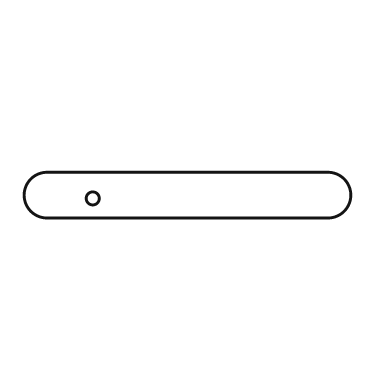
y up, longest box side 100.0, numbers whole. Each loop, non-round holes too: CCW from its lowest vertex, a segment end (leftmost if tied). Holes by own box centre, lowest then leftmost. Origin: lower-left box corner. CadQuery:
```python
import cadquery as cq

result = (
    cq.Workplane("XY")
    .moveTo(7.0, 0.0)
    .lineTo(93.0, 0.0)
    .threePointArc((100.0, 7.0), (93.0, 14.0))
    .lineTo(7.0, 14.0)
    .threePointArc((0.0, 7.0), (7.0, 0.0))
    .close()
    .moveTo(21.0, 6.0)
    .circle(2.0)
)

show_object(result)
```